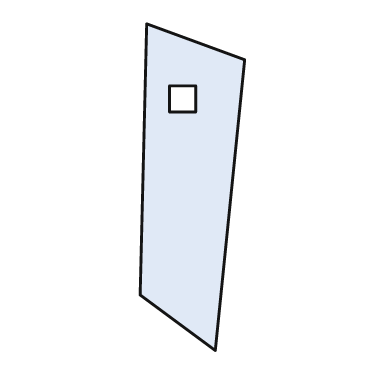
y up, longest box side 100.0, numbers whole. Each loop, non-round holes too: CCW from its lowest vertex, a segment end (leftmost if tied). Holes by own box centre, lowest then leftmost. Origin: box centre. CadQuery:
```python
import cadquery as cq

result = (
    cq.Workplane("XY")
    .moveTo(7.0, -50.0)
    .lineTo(16.0, 39.0)
    .lineTo(-14.0, 50.0)
    .lineTo(-16.0, -33.0)
    .close()
    .moveTo(-7.0, 23.0)
    .lineTo(1.0, 23.0)
    .lineTo(1.0, 31.0)
    .lineTo(-7.0, 31.0)
    .close()
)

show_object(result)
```